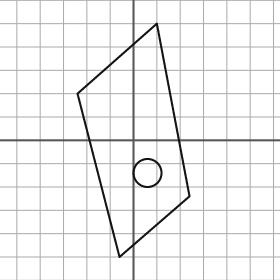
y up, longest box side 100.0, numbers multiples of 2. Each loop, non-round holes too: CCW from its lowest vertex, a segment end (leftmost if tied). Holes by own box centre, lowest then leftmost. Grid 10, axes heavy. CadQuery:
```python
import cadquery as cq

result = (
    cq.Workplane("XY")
    .moveTo(-6.0, -50.0)
    .lineTo(24.0, -24.0)
    .lineTo(10.0, 50.0)
    .lineTo(-24.0, 20.0)
    .close()
    .moveTo(6.0, -14.0)
    .circle(6.0)
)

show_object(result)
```